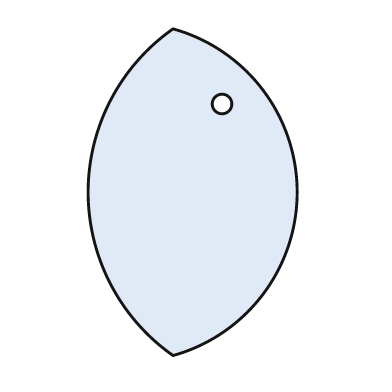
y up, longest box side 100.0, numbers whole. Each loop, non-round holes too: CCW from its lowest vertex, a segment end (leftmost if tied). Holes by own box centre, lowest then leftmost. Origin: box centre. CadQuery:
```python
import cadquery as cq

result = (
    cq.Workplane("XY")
    .moveTo(-6.0, -50.0)
    .threePointArc((32.0, 0.0), (-6.0, 50.0))
    .threePointArc((-32.0, 0.0), (-6.0, -50.0))
    .close()
    .moveTo(9.0, 27.0)
    .circle(3.0)
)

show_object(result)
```